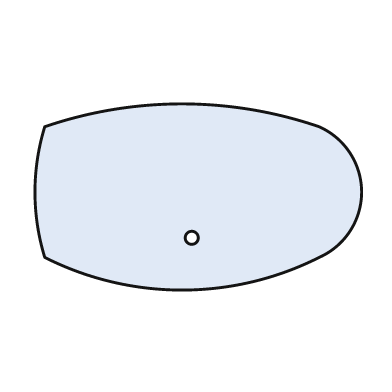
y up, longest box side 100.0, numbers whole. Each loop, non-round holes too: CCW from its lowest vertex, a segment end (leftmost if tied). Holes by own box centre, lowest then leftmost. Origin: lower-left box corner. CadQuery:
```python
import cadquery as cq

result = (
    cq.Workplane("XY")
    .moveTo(3.0, 10.0)
    .threePointArc((45.0, 0.0), (87.0, 10.0))
    .threePointArc((100.0, 30.0), (87.0, 50.0))
    .threePointArc((45.0, 57.0), (3.0, 50.0))
    .threePointArc((0.0, 30.0), (3.0, 10.0))
    .close()
    .moveTo(48.0, 16.0)
    .circle(2.0)
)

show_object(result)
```